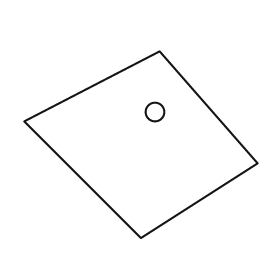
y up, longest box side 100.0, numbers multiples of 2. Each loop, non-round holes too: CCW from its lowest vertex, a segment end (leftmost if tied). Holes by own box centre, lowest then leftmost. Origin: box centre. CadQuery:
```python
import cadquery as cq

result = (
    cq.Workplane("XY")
    .moveTo(0.0, -40.0)
    .lineTo(50.0, -8.0)
    .lineTo(8.0, 40.0)
    .lineTo(-50.0, 10.0)
    .close()
    .moveTo(6.0, 14.0)
    .circle(4.0)
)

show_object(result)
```